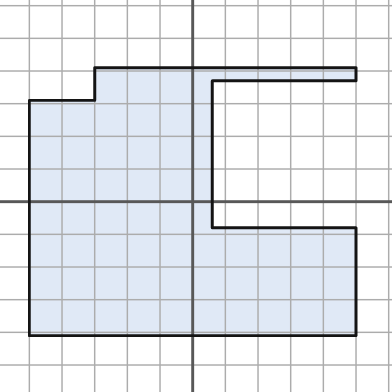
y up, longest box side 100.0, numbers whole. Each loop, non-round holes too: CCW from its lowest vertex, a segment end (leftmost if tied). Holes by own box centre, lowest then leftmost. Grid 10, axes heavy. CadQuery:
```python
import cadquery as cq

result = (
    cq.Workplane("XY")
    .moveTo(-50.0, -41.0)
    .lineTo(50.0, -41.0)
    .lineTo(50.0, -8.0)
    .lineTo(6.0, -8.0)
    .lineTo(6.0, 37.0)
    .lineTo(50.0, 37.0)
    .lineTo(50.0, 41.0)
    .lineTo(-30.0, 41.0)
    .lineTo(-30.0, 31.0)
    .lineTo(-50.0, 31.0)
    .close()
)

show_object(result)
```